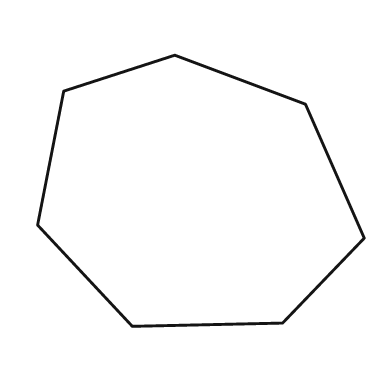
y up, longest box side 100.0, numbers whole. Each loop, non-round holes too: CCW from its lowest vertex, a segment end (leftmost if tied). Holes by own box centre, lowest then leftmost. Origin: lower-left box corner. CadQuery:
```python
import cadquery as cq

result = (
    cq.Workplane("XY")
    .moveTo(29.0, 0.0)
    .lineTo(75.0, 1.0)
    .lineTo(100.0, 27.0)
    .lineTo(82.0, 68.0)
    .lineTo(42.0, 83.0)
    .lineTo(8.0, 72.0)
    .lineTo(0.0, 31.0)
    .close()
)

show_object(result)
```